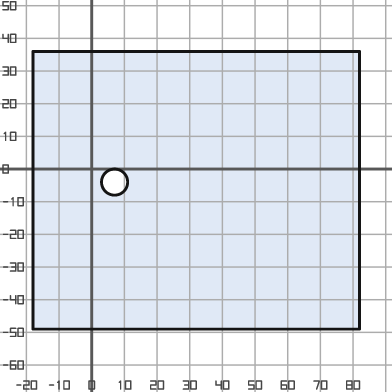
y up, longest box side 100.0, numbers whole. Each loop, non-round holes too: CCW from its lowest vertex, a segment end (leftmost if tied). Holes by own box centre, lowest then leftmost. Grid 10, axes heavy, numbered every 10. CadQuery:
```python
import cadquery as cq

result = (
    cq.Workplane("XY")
    .moveTo(-18.0, -49.0)
    .lineTo(82.0, -49.0)
    .lineTo(82.0, 36.0)
    .lineTo(-18.0, 36.0)
    .close()
    .moveTo(7.0, -4.0)
    .circle(4.0)
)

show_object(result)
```